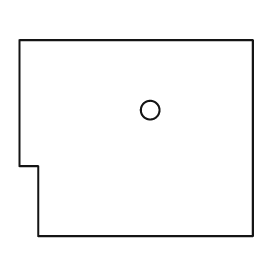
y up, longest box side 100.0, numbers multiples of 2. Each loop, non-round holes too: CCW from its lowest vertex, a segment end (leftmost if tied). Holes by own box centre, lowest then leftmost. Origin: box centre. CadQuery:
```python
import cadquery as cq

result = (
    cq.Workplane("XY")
    .moveTo(-42.0, -42.0)
    .lineTo(50.0, -42.0)
    .lineTo(50.0, 42.0)
    .lineTo(-50.0, 42.0)
    .lineTo(-50.0, -12.0)
    .lineTo(-42.0, -12.0)
    .close()
    .moveTo(6.0, 12.0)
    .circle(4.0)
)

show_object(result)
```